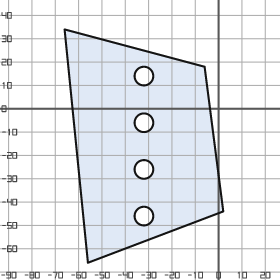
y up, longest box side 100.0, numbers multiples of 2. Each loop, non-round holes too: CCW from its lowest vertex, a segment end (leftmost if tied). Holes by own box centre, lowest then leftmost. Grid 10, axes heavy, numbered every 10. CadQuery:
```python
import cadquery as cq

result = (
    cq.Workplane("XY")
    .moveTo(-56.0, -66.0)
    .lineTo(2.0, -44.0)
    .lineTo(-6.0, 18.0)
    .lineTo(-66.0, 34.0)
    .close()
    .moveTo(-32.0, -46.0)
    .circle(4.0)
    .moveTo(-32.0, -26.0)
    .circle(4.0)
    .moveTo(-32.0, -6.0)
    .circle(4.0)
    .moveTo(-32.0, 14.0)
    .circle(4.0)
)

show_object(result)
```